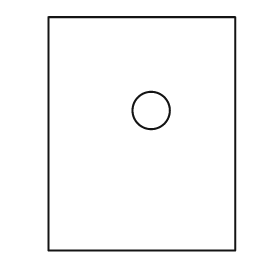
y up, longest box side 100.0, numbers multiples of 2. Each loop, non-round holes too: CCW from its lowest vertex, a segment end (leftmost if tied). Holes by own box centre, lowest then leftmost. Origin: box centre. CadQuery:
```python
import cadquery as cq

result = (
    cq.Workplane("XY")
    .moveTo(-40.0, -50.0)
    .lineTo(40.0, -50.0)
    .lineTo(40.0, 50.0)
    .lineTo(-40.0, 50.0)
    .close()
    .moveTo(4.0, 10.0)
    .circle(8.0)
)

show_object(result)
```